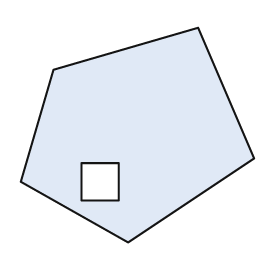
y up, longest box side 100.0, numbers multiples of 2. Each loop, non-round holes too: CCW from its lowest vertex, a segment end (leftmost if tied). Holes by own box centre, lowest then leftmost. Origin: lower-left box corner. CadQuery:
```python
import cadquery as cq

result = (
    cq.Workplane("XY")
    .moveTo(46.0, 0.0)
    .lineTo(100.0, 36.0)
    .lineTo(76.0, 92.0)
    .lineTo(14.0, 74.0)
    .lineTo(0.0, 26.0)
    .close()
    .moveTo(26.0, 18.0)
    .lineTo(42.0, 18.0)
    .lineTo(42.0, 34.0)
    .lineTo(26.0, 34.0)
    .close()
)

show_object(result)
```